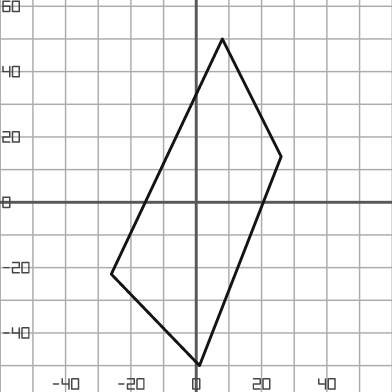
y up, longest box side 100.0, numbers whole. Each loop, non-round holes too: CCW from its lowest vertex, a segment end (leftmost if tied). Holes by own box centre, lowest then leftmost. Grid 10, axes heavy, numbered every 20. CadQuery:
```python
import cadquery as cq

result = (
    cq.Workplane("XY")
    .moveTo(1.0, -50.0)
    .lineTo(26.0, 14.0)
    .lineTo(8.0, 50.0)
    .lineTo(-26.0, -22.0)
    .close()
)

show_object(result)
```